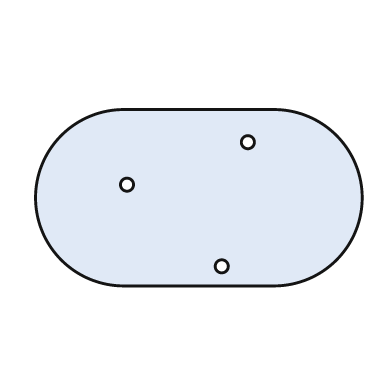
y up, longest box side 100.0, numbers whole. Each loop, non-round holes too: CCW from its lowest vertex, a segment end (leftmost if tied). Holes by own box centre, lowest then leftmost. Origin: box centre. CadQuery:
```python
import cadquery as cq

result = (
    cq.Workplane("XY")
    .moveTo(-23.0, -27.0)
    .lineTo(23.0, -27.0)
    .threePointArc((50.0, 0.0), (23.0, 27.0))
    .lineTo(-23.0, 27.0)
    .threePointArc((-50.0, 0.0), (-23.0, -27.0))
    .close()
    .moveTo(7.0, -21.0)
    .circle(2.0)
    .moveTo(-22.0, 4.0)
    .circle(2.0)
    .moveTo(15.0, 17.0)
    .circle(2.0)
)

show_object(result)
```